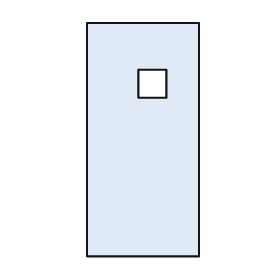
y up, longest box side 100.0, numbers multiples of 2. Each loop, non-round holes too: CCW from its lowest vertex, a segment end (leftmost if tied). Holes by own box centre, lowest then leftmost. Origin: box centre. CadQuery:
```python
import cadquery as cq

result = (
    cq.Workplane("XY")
    .moveTo(-24.0, -50.0)
    .lineTo(24.0, -50.0)
    .lineTo(24.0, 50.0)
    .lineTo(-24.0, 50.0)
    .close()
    .moveTo(-2.0, 18.0)
    .lineTo(10.0, 18.0)
    .lineTo(10.0, 30.0)
    .lineTo(-2.0, 30.0)
    .close()
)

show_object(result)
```